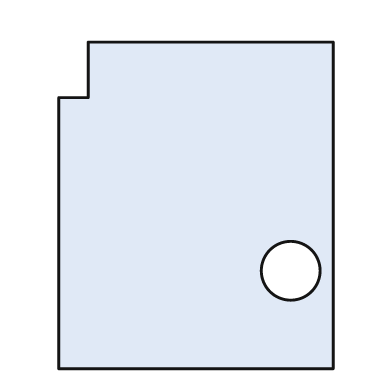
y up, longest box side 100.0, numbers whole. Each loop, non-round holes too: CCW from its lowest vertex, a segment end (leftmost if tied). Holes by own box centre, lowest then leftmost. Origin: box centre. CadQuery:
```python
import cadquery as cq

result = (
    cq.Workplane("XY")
    .moveTo(-42.0, -50.0)
    .lineTo(42.0, -50.0)
    .lineTo(42.0, 50.0)
    .lineTo(-33.0, 50.0)
    .lineTo(-33.0, 33.0)
    .lineTo(-42.0, 33.0)
    .close()
    .moveTo(29.0, -20.0)
    .circle(9.0)
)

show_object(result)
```